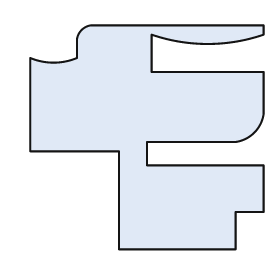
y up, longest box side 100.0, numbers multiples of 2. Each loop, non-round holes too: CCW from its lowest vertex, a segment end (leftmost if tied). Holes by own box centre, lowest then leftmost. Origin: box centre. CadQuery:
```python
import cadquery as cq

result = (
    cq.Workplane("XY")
    .moveTo(-12.0, -48.0)
    .lineTo(38.0, -48.0)
    .lineTo(38.0, -32.0)
    .lineTo(50.0, -32.0)
    .lineTo(50.0, -12.0)
    .lineTo(0.0, -12.0)
    .lineTo(0.0, -2.0)
    .lineTo(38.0, -2.0)
    .threePointArc((46.0, 2.0), (50.0, 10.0))
    .lineTo(50.0, 28.0)
    .lineTo(2.0, 28.0)
    .lineTo(2.0, 44.0)
    .threePointArc((26.0, 40.0), (50.0, 44.0))
    .lineTo(50.0, 48.0)
    .lineTo(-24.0, 48.0)
    .threePointArc((-28.0, 46.0), (-30.0, 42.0))
    .lineTo(-30.0, 34.0)
    .threePointArc((-40.0, 32.0), (-50.0, 34.0))
    .lineTo(-50.0, -6.0)
    .lineTo(-12.0, -6.0)
    .close()
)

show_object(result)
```